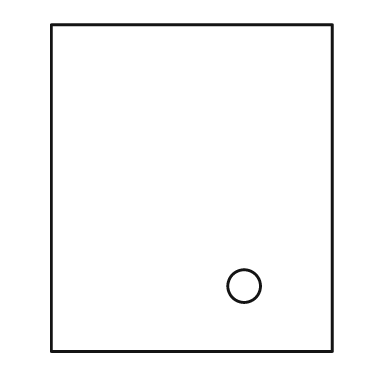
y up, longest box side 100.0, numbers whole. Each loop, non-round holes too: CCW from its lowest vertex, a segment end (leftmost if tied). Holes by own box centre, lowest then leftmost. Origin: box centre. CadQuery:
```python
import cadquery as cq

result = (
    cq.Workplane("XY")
    .moveTo(-43.0, -50.0)
    .lineTo(43.0, -50.0)
    .lineTo(43.0, 50.0)
    .lineTo(-43.0, 50.0)
    .close()
    .moveTo(16.0, -30.0)
    .circle(5.0)
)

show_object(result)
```